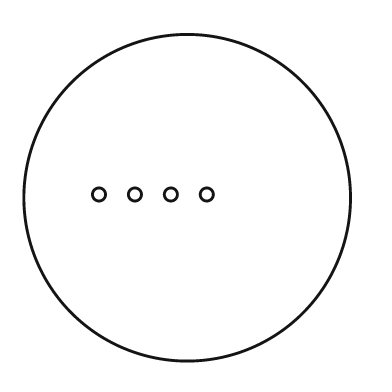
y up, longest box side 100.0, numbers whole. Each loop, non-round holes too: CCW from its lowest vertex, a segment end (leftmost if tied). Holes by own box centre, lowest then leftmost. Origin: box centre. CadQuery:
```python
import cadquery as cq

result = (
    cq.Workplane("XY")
    .moveTo(0.0, 0.0)
    .circle(50.0)
    .moveTo(-27.0, 1.0)
    .circle(2.0)
    .moveTo(-16.0, 1.0)
    .circle(2.0)
    .moveTo(-5.0, 1.0)
    .circle(2.0)
    .moveTo(6.0, 1.0)
    .circle(2.0)
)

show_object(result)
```